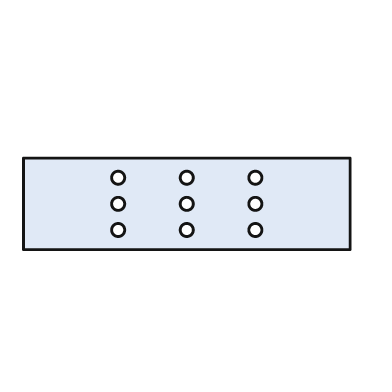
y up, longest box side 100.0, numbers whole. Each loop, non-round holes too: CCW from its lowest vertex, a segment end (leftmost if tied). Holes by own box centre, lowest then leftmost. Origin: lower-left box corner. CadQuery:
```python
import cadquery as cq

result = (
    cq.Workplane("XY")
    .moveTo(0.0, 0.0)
    .lineTo(100.0, 0.0)
    .lineTo(100.0, 28.0)
    .lineTo(0.0, 28.0)
    .close()
    .moveTo(29.0, 6.0)
    .circle(2.0)
    .moveTo(50.0, 6.0)
    .circle(2.0)
    .moveTo(71.0, 6.0)
    .circle(2.0)
    .moveTo(29.0, 14.0)
    .circle(2.0)
    .moveTo(50.0, 14.0)
    .circle(2.0)
    .moveTo(71.0, 14.0)
    .circle(2.0)
    .moveTo(29.0, 22.0)
    .circle(2.0)
    .moveTo(50.0, 22.0)
    .circle(2.0)
    .moveTo(71.0, 22.0)
    .circle(2.0)
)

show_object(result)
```